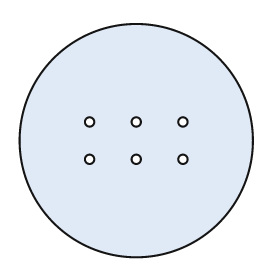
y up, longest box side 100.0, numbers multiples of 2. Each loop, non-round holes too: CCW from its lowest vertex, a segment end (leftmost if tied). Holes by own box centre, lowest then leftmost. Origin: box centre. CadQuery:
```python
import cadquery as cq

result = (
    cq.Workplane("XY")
    .moveTo(0.0, 0.0)
    .circle(50.0)
    .moveTo(-20.0, -8.0)
    .circle(2.0)
    .moveTo(0.0, -8.0)
    .circle(2.0)
    .moveTo(20.0, -8.0)
    .circle(2.0)
    .moveTo(-20.0, 8.0)
    .circle(2.0)
    .moveTo(0.0, 8.0)
    .circle(2.0)
    .moveTo(20.0, 8.0)
    .circle(2.0)
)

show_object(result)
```